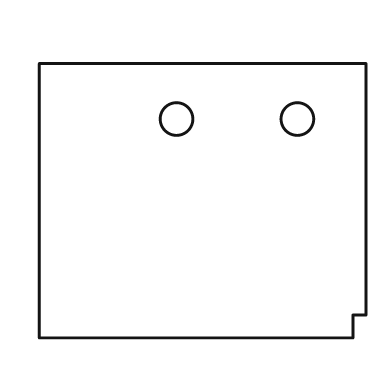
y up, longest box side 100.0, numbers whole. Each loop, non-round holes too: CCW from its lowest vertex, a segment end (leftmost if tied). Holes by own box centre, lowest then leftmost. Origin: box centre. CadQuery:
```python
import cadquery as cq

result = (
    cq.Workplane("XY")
    .moveTo(-50.0, -42.0)
    .lineTo(46.0, -42.0)
    .lineTo(46.0, -35.0)
    .lineTo(50.0, -35.0)
    .lineTo(50.0, 42.0)
    .lineTo(-50.0, 42.0)
    .close()
    .moveTo(-8.0, 25.0)
    .circle(5.0)
    .moveTo(29.0, 25.0)
    .circle(5.0)
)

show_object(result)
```